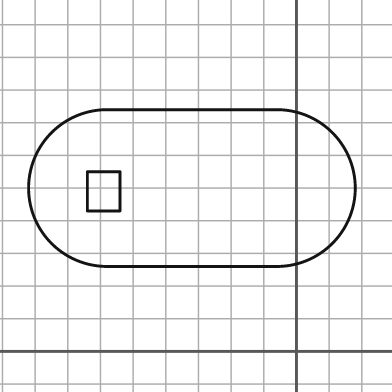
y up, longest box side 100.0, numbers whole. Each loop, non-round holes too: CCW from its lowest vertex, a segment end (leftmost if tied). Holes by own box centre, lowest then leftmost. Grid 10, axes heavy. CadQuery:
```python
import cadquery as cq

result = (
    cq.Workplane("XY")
    .moveTo(-58.0, 26.0)
    .lineTo(-6.0, 26.0)
    .threePointArc((18.0, 50.0), (-6.0, 74.0))
    .lineTo(-58.0, 74.0)
    .threePointArc((-82.0, 50.0), (-58.0, 26.0))
    .close()
    .moveTo(-64.0, 43.0)
    .lineTo(-54.0, 43.0)
    .lineTo(-54.0, 55.0)
    .lineTo(-64.0, 55.0)
    .close()
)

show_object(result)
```